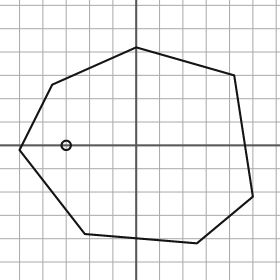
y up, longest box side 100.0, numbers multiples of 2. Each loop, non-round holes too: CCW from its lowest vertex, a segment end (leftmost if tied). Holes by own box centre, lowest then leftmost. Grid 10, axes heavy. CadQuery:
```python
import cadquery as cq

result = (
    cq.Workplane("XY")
    .moveTo(26.0, -42.0)
    .lineTo(50.0, -22.0)
    .lineTo(42.0, 30.0)
    .lineTo(0.0, 42.0)
    .lineTo(-36.0, 26.0)
    .lineTo(-50.0, -2.0)
    .lineTo(-22.0, -38.0)
    .close()
    .moveTo(-30.0, 0.0)
    .circle(2.0)
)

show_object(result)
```